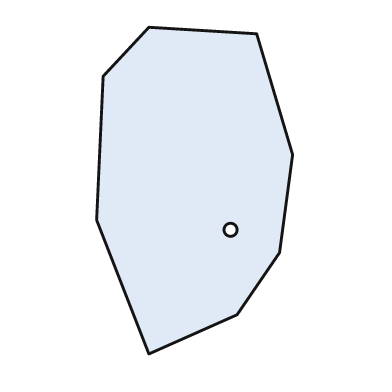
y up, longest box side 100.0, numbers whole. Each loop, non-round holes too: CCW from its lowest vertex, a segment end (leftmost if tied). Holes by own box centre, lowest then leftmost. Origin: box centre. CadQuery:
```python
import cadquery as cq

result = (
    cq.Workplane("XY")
    .moveTo(-14.0, -50.0)
    .lineTo(13.0, -38.0)
    .lineTo(26.0, -19.0)
    .lineTo(30.0, 11.0)
    .lineTo(19.0, 48.0)
    .lineTo(-14.0, 50.0)
    .lineTo(-28.0, 35.0)
    .lineTo(-30.0, -9.0)
    .close()
    .moveTo(11.0, -12.0)
    .circle(2.0)
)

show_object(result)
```